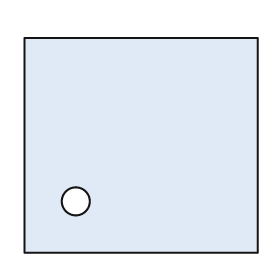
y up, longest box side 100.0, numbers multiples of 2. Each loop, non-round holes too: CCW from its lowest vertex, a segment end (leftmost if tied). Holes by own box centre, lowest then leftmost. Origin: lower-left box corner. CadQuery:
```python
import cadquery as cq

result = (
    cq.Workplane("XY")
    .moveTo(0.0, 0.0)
    .lineTo(100.0, 0.0)
    .lineTo(100.0, 92.0)
    .lineTo(0.0, 92.0)
    .close()
    .moveTo(22.0, 22.0)
    .circle(6.0)
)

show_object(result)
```